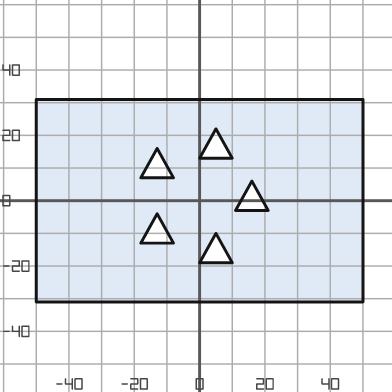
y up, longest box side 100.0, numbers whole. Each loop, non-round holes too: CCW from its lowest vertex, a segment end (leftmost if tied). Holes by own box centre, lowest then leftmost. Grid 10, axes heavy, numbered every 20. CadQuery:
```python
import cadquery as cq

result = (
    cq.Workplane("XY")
    .moveTo(-50.0, -31.0)
    .lineTo(50.0, -31.0)
    .lineTo(50.0, 31.0)
    .lineTo(-50.0, 31.0)
    .close()
    .moveTo(0.0, -19.0)
    .lineTo(10.0, -19.0)
    .lineTo(5.0, -10.0)
    .close()
    .moveTo(-18.0, -13.0)
    .lineTo(-8.0, -13.0)
    .lineTo(-13.0, -4.0)
    .close()
    .moveTo(11.0, -3.0)
    .lineTo(21.0, -3.0)
    .lineTo(16.0, 6.0)
    .close()
    .moveTo(-18.0, 7.0)
    .lineTo(-8.0, 7.0)
    .lineTo(-13.0, 16.0)
    .close()
    .moveTo(0.0, 13.0)
    .lineTo(10.0, 13.0)
    .lineTo(5.0, 22.0)
    .close()
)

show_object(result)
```